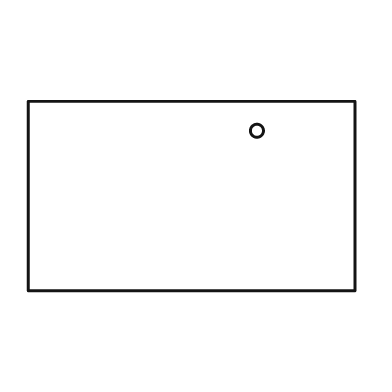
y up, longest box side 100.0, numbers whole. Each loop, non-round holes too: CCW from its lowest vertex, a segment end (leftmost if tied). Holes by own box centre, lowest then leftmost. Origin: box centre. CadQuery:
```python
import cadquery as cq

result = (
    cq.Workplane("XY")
    .moveTo(-50.0, -29.0)
    .lineTo(50.0, -29.0)
    .lineTo(50.0, 29.0)
    .lineTo(-50.0, 29.0)
    .close()
    .moveTo(20.0, 20.0)
    .circle(2.0)
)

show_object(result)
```